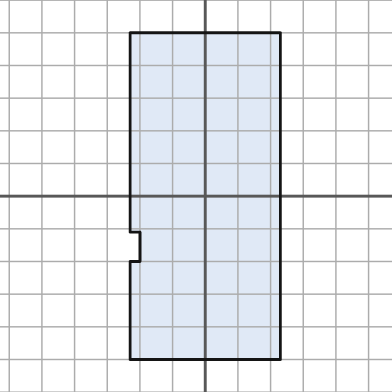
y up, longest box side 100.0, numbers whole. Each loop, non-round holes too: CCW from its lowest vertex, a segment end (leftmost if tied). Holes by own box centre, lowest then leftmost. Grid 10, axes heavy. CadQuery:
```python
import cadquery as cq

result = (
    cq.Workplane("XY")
    .moveTo(-23.0, -50.0)
    .lineTo(23.0, -50.0)
    .lineTo(23.0, 50.0)
    .lineTo(-23.0, 50.0)
    .lineTo(-23.0, -11.0)
    .lineTo(-20.0, -11.0)
    .lineTo(-20.0, -20.0)
    .lineTo(-23.0, -20.0)
    .close()
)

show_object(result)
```